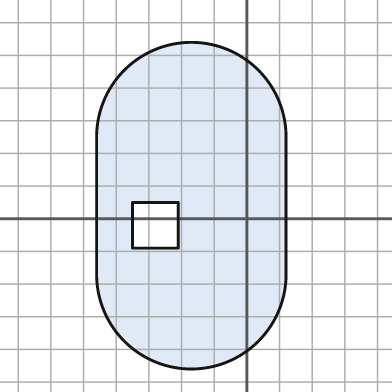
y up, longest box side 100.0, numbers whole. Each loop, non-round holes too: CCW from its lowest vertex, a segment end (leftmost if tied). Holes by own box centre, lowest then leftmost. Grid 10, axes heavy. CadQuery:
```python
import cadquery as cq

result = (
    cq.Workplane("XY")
    .moveTo(-46.0, -17.0)
    .threePointArc((-17.0, -46.0), (12.0, -17.0))
    .lineTo(12.0, 25.0)
    .threePointArc((-17.0, 54.0), (-46.0, 25.0))
    .close()
    .moveTo(-35.0, -9.0)
    .lineTo(-21.0, -9.0)
    .lineTo(-21.0, 5.0)
    .lineTo(-35.0, 5.0)
    .close()
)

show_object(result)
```